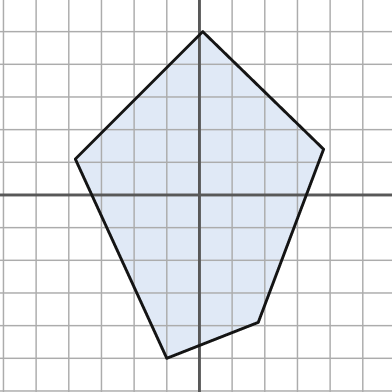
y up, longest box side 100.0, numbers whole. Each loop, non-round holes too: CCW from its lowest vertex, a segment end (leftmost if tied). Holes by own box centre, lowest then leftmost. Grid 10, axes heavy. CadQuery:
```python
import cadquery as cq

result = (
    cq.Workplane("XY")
    .moveTo(-10.0, -50.0)
    .lineTo(18.0, -39.0)
    .lineTo(38.0, 14.0)
    .lineTo(1.0, 50.0)
    .lineTo(-38.0, 11.0)
    .close()
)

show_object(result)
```